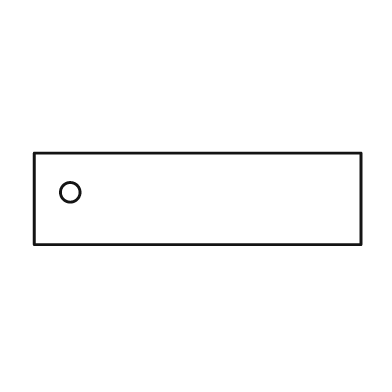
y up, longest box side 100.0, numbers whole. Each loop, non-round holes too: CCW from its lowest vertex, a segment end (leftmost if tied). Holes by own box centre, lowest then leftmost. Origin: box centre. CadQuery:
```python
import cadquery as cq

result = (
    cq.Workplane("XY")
    .moveTo(-50.0, -14.0)
    .lineTo(50.0, -14.0)
    .lineTo(50.0, 14.0)
    .lineTo(-50.0, 14.0)
    .close()
    .moveTo(-39.0, 2.0)
    .circle(3.0)
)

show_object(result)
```